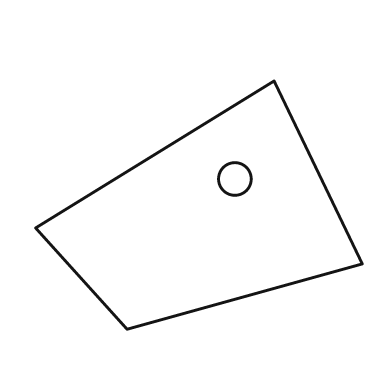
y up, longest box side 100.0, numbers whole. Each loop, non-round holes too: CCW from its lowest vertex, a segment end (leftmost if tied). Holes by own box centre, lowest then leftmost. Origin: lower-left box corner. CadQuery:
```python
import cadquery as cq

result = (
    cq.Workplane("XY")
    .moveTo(28.0, 0.0)
    .lineTo(100.0, 20.0)
    .lineTo(73.0, 76.0)
    .lineTo(0.0, 31.0)
    .close()
    .moveTo(61.0, 46.0)
    .circle(5.0)
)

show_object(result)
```